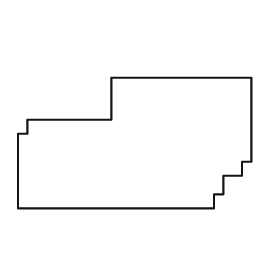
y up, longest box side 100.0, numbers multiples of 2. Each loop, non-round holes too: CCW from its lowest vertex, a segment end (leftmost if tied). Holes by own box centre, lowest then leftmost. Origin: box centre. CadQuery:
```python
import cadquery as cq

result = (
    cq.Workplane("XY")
    .moveTo(-50.0, -28.0)
    .lineTo(34.0, -28.0)
    .lineTo(34.0, -22.0)
    .lineTo(38.0, -22.0)
    .lineTo(38.0, -14.0)
    .lineTo(46.0, -14.0)
    .lineTo(46.0, -8.0)
    .lineTo(50.0, -8.0)
    .lineTo(50.0, 28.0)
    .lineTo(-10.0, 28.0)
    .lineTo(-10.0, 10.0)
    .lineTo(-46.0, 10.0)
    .lineTo(-46.0, 4.0)
    .lineTo(-50.0, 4.0)
    .close()
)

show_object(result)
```